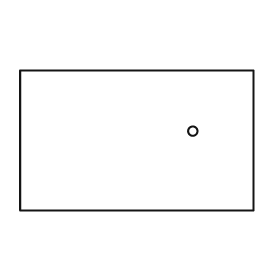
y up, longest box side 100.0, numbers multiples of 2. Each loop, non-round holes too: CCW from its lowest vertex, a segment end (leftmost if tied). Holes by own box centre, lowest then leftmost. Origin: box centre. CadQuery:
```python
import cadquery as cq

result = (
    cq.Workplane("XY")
    .moveTo(-50.0, -30.0)
    .lineTo(50.0, -30.0)
    .lineTo(50.0, 30.0)
    .lineTo(-50.0, 30.0)
    .close()
    .moveTo(24.0, 4.0)
    .circle(2.0)
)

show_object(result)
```